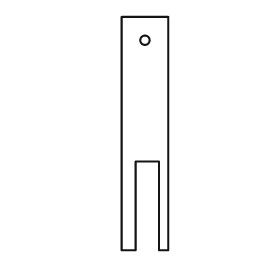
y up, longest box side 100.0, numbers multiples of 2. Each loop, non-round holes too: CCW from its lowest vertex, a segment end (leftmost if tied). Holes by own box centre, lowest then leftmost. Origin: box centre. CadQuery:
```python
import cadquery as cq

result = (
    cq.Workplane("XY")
    .moveTo(-10.0, -50.0)
    .lineTo(-4.0, -50.0)
    .lineTo(-4.0, -12.0)
    .lineTo(6.0, -12.0)
    .lineTo(6.0, -50.0)
    .lineTo(10.0, -50.0)
    .lineTo(10.0, 50.0)
    .lineTo(-10.0, 50.0)
    .close()
    .moveTo(0.0, 40.0)
    .circle(2.0)
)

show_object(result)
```